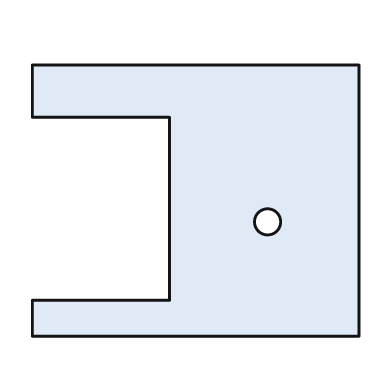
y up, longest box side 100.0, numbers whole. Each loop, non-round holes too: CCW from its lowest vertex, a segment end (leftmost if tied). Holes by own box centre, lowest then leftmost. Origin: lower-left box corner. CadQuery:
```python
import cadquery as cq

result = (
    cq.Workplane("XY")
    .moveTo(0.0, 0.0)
    .lineTo(100.0, 0.0)
    .lineTo(100.0, 83.0)
    .lineTo(0.0, 83.0)
    .lineTo(0.0, 67.0)
    .lineTo(42.0, 67.0)
    .lineTo(42.0, 11.0)
    .lineTo(0.0, 11.0)
    .close()
    .moveTo(72.0, 35.0)
    .circle(4.0)
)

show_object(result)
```